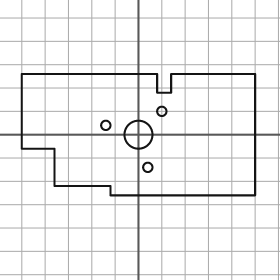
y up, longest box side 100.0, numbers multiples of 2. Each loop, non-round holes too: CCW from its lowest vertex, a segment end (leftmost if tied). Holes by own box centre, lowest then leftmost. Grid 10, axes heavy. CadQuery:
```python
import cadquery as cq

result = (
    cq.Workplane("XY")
    .moveTo(-12.0, -26.0)
    .lineTo(50.0, -26.0)
    .lineTo(50.0, 26.0)
    .lineTo(14.0, 26.0)
    .lineTo(14.0, 18.0)
    .lineTo(8.0, 18.0)
    .lineTo(8.0, 26.0)
    .lineTo(-50.0, 26.0)
    .lineTo(-50.0, -6.0)
    .lineTo(-36.0, -6.0)
    .lineTo(-36.0, -22.0)
    .lineTo(-12.0, -22.0)
    .close()
    .moveTo(4.0, -14.0)
    .circle(2.0)
    .moveTo(0.0, 0.0)
    .circle(6.0)
    .moveTo(-14.0, 4.0)
    .circle(2.0)
    .moveTo(10.0, 10.0)
    .circle(2.0)
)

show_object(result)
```